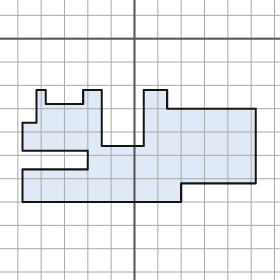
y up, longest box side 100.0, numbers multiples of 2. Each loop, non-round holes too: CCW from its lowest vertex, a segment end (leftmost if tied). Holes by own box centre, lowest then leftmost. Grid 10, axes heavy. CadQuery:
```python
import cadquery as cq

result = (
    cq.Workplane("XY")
    .moveTo(-48.0, -70.0)
    .lineTo(20.0, -70.0)
    .lineTo(20.0, -62.0)
    .lineTo(52.0, -62.0)
    .lineTo(52.0, -30.0)
    .lineTo(14.0, -30.0)
    .lineTo(14.0, -22.0)
    .lineTo(4.0, -22.0)
    .lineTo(4.0, -46.0)
    .lineTo(-14.0, -46.0)
    .lineTo(-14.0, -22.0)
    .lineTo(-22.0, -22.0)
    .lineTo(-22.0, -28.0)
    .lineTo(-38.0, -28.0)
    .lineTo(-38.0, -22.0)
    .lineTo(-42.0, -22.0)
    .lineTo(-42.0, -36.0)
    .lineTo(-48.0, -36.0)
    .lineTo(-48.0, -48.0)
    .lineTo(-20.0, -48.0)
    .lineTo(-20.0, -56.0)
    .lineTo(-48.0, -56.0)
    .close()
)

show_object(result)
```